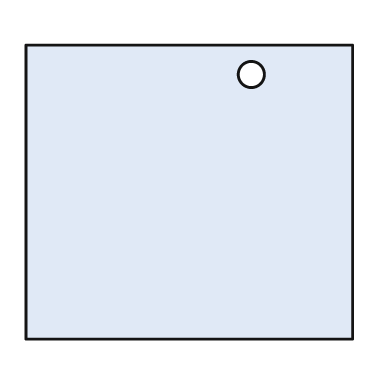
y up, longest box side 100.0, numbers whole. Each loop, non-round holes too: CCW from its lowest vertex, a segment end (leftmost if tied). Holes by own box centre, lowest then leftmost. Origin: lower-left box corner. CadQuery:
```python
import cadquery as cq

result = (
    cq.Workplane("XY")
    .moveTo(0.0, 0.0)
    .lineTo(100.0, 0.0)
    .lineTo(100.0, 90.0)
    .lineTo(0.0, 90.0)
    .close()
    .moveTo(69.0, 81.0)
    .circle(4.0)
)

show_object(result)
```